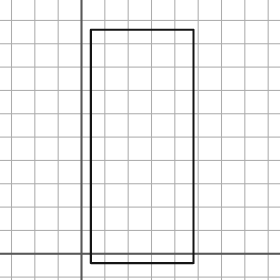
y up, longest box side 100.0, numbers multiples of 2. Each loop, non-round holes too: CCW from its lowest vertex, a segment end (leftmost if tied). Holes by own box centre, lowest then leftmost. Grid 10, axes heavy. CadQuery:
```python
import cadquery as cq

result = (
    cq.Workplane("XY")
    .moveTo(4.0, -4.0)
    .lineTo(48.0, -4.0)
    .lineTo(48.0, 96.0)
    .lineTo(4.0, 96.0)
    .close()
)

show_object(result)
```